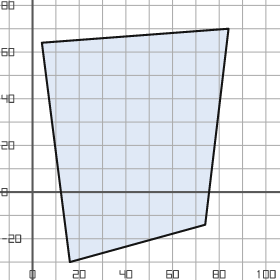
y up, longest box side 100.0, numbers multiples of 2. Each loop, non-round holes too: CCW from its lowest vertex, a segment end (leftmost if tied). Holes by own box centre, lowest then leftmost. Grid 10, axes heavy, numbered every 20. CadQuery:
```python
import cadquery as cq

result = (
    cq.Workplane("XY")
    .moveTo(16.0, -30.0)
    .lineTo(74.0, -14.0)
    .lineTo(84.0, 70.0)
    .lineTo(4.0, 64.0)
    .close()
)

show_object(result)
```